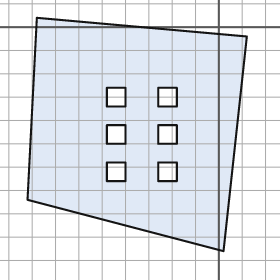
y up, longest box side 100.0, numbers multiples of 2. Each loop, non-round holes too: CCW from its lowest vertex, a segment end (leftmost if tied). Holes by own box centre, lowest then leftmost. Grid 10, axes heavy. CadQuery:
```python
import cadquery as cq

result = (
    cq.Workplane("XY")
    .moveTo(2.0, -96.0)
    .lineTo(12.0, -4.0)
    .lineTo(-78.0, 4.0)
    .lineTo(-82.0, -74.0)
    .close()
    .moveTo(-48.0, -66.0)
    .lineTo(-40.0, -66.0)
    .lineTo(-40.0, -58.0)
    .lineTo(-48.0, -58.0)
    .close()
    .moveTo(-26.0, -66.0)
    .lineTo(-18.0, -66.0)
    .lineTo(-18.0, -58.0)
    .lineTo(-26.0, -58.0)
    .close()
    .moveTo(-48.0, -50.0)
    .lineTo(-40.0, -50.0)
    .lineTo(-40.0, -42.0)
    .lineTo(-48.0, -42.0)
    .close()
    .moveTo(-26.0, -50.0)
    .lineTo(-18.0, -50.0)
    .lineTo(-18.0, -42.0)
    .lineTo(-26.0, -42.0)
    .close()
    .moveTo(-48.0, -34.0)
    .lineTo(-40.0, -34.0)
    .lineTo(-40.0, -26.0)
    .lineTo(-48.0, -26.0)
    .close()
    .moveTo(-26.0, -34.0)
    .lineTo(-18.0, -34.0)
    .lineTo(-18.0, -26.0)
    .lineTo(-26.0, -26.0)
    .close()
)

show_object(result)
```